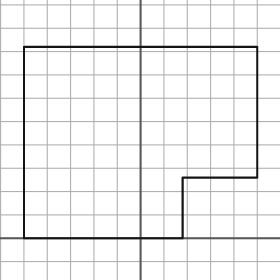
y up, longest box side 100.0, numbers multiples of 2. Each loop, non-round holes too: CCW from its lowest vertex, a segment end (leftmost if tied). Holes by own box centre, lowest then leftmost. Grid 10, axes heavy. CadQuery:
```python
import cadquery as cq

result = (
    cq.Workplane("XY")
    .moveTo(-50.0, 0.0)
    .lineTo(18.0, 0.0)
    .lineTo(18.0, 26.0)
    .lineTo(50.0, 26.0)
    .lineTo(50.0, 82.0)
    .lineTo(-50.0, 82.0)
    .close()
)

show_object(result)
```